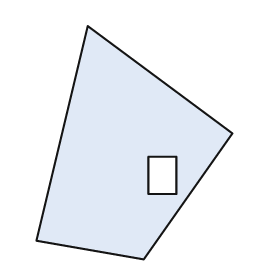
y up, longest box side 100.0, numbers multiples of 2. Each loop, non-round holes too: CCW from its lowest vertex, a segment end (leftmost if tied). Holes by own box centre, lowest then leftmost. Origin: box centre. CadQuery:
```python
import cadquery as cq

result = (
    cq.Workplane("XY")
    .moveTo(4.0, -50.0)
    .lineTo(42.0, 4.0)
    .lineTo(-20.0, 50.0)
    .lineTo(-42.0, -42.0)
    .close()
    .moveTo(6.0, -22.0)
    .lineTo(18.0, -22.0)
    .lineTo(18.0, -6.0)
    .lineTo(6.0, -6.0)
    .close()
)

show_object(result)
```